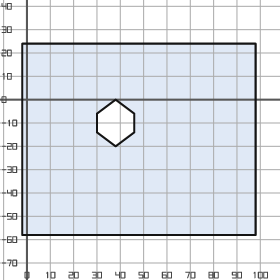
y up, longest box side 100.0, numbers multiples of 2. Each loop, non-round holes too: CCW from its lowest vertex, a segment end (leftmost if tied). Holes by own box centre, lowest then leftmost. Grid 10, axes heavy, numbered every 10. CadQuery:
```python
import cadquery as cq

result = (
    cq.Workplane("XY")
    .moveTo(-2.0, -58.0)
    .lineTo(98.0, -58.0)
    .lineTo(98.0, 24.0)
    .lineTo(-2.0, 24.0)
    .close()
    .moveTo(38.0, -20.0)
    .lineTo(46.0, -14.0)
    .lineTo(46.0, -6.0)
    .lineTo(38.0, 0.0)
    .lineTo(30.0, -6.0)
    .lineTo(30.0, -14.0)
    .close()
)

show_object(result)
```